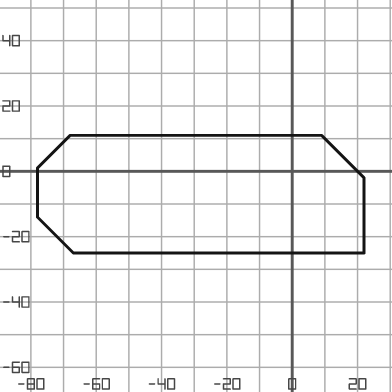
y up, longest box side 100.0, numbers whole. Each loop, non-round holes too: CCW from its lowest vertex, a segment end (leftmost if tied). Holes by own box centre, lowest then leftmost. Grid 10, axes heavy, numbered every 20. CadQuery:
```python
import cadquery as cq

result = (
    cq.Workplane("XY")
    .moveTo(-67.0, -25.0)
    .lineTo(22.0, -25.0)
    .lineTo(22.0, -2.0)
    .lineTo(9.0, 11.0)
    .lineTo(-68.0, 11.0)
    .lineTo(-78.0, 1.0)
    .lineTo(-78.0, -14.0)
    .close()
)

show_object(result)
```